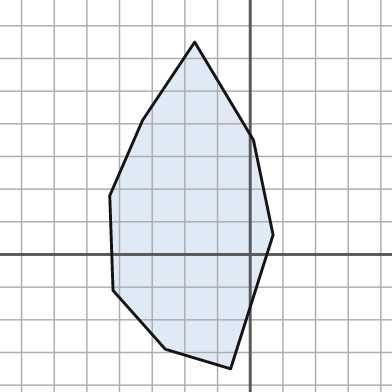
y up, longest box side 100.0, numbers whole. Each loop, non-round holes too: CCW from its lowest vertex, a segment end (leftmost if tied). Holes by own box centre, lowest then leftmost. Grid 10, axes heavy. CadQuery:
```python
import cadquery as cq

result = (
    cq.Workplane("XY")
    .moveTo(-6.0, -35.0)
    .lineTo(7.0, 6.0)
    .lineTo(1.0, 35.0)
    .lineTo(-17.0, 65.0)
    .lineTo(-33.0, 41.0)
    .lineTo(-43.0, 18.0)
    .lineTo(-42.0, -11.0)
    .lineTo(-26.0, -29.0)
    .close()
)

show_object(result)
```